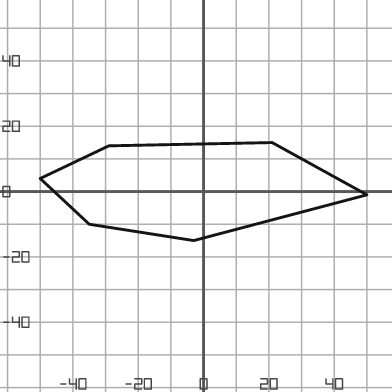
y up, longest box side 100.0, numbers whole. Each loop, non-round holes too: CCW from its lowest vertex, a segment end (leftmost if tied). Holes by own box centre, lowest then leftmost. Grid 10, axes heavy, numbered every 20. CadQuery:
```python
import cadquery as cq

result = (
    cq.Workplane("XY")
    .moveTo(-3.0, -15.0)
    .lineTo(50.0, -1.0)
    .lineTo(21.0, 15.0)
    .lineTo(-29.0, 14.0)
    .lineTo(-50.0, 4.0)
    .lineTo(-35.0, -10.0)
    .close()
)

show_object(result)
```